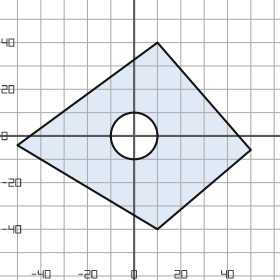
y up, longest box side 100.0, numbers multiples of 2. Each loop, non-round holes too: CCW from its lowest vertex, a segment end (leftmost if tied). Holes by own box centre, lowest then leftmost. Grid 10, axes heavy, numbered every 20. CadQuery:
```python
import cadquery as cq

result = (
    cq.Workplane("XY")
    .moveTo(10.0, -40.0)
    .lineTo(50.0, -6.0)
    .lineTo(10.0, 40.0)
    .lineTo(-50.0, -4.0)
    .close()
    .moveTo(0.0, 0.0)
    .circle(10.0)
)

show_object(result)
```